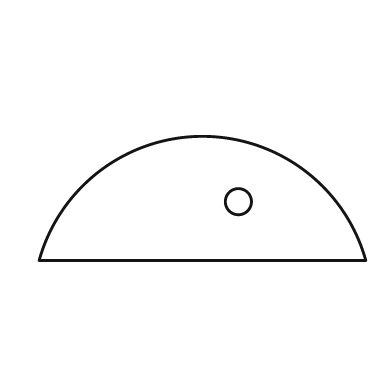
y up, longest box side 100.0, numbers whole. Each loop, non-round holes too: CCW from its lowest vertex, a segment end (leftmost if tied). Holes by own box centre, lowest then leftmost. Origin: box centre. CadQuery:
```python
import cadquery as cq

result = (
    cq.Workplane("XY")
    .moveTo(-50.0, -19.0)
    .lineTo(50.0, -19.0)
    .threePointArc((0.0, 19.0), (-50.0, -19.0))
    .close()
    .moveTo(11.0, -1.0)
    .circle(4.0)
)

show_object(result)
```